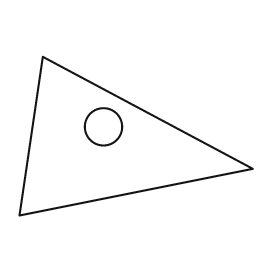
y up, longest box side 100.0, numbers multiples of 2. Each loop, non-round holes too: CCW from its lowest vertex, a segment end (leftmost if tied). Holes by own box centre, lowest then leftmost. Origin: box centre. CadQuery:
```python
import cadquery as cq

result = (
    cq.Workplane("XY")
    .moveTo(-50.0, -34.0)
    .lineTo(50.0, -14.0)
    .lineTo(-40.0, 34.0)
    .close()
    .moveTo(-14.0, 4.0)
    .circle(8.0)
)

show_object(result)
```